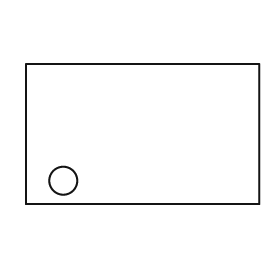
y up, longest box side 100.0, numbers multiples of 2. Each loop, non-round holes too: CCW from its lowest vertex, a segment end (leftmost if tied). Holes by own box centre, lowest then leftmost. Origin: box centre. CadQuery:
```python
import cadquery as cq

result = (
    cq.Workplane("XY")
    .moveTo(-50.0, -30.0)
    .lineTo(50.0, -30.0)
    .lineTo(50.0, 30.0)
    .lineTo(-50.0, 30.0)
    .close()
    .moveTo(-34.0, -20.0)
    .circle(6.0)
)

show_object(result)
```